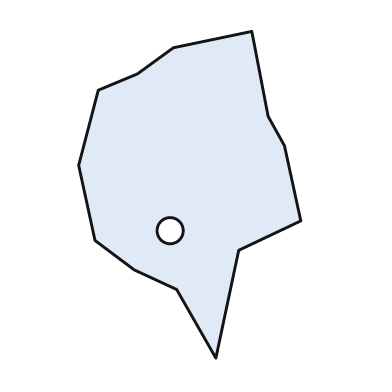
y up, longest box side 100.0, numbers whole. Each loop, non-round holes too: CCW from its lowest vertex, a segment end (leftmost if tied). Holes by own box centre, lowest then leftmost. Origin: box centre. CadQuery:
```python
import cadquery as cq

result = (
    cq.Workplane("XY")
    .moveTo(8.0, -50.0)
    .lineTo(15.0, -17.0)
    .lineTo(34.0, -8.0)
    .lineTo(29.0, 15.0)
    .lineTo(24.0, 24.0)
    .lineTo(19.0, 50.0)
    .lineTo(-5.0, 45.0)
    .lineTo(-16.0, 37.0)
    .lineTo(-28.0, 32.0)
    .lineTo(-34.0, 9.0)
    .lineTo(-29.0, -14.0)
    .lineTo(-17.0, -23.0)
    .lineTo(-4.0, -29.0)
    .close()
    .moveTo(-6.0, -11.0)
    .circle(4.0)
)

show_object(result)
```